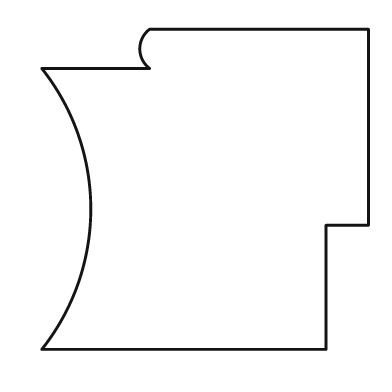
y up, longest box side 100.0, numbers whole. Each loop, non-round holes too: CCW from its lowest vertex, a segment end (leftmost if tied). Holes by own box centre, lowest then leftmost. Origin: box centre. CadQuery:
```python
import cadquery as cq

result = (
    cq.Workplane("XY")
    .moveTo(-50.0, -49.0)
    .lineTo(37.0, -49.0)
    .lineTo(37.0, -11.0)
    .lineTo(50.0, -11.0)
    .lineTo(50.0, 49.0)
    .lineTo(-17.0, 49.0)
    .threePointArc((-20.0, 43.0), (-17.0, 37.0))
    .lineTo(-50.0, 37.0)
    .threePointArc((-35.0, -6.0), (-50.0, -49.0))
    .close()
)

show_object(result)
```